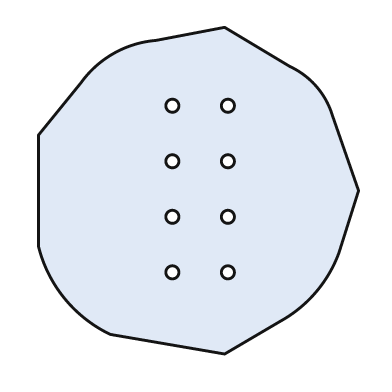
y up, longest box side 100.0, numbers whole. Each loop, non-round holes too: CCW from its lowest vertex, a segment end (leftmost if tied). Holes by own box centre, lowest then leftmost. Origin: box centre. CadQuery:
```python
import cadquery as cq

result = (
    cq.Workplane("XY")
    .moveTo(8.0, -50.0)
    .lineTo(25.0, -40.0)
    .threePointArc((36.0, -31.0), (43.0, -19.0))
    .lineTo(49.0, 0.0)
    .lineTo(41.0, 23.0)
    .threePointArc((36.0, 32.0), (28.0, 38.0))
    .lineTo(8.0, 50.0)
    .lineTo(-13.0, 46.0)
    .threePointArc((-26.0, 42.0), (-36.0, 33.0))
    .lineTo(-49.0, 17.0)
    .lineTo(-49.0, -17.0)
    .threePointArc((-41.0, -33.0), (-27.0, -44.0))
    .close()
    .moveTo(-8.0, -25.0)
    .circle(2.0)
    .moveTo(9.0, -25.0)
    .circle(2.0)
    .moveTo(-8.0, -8.0)
    .circle(2.0)
    .moveTo(9.0, -8.0)
    .circle(2.0)
    .moveTo(-8.0, 9.0)
    .circle(2.0)
    .moveTo(9.0, 9.0)
    .circle(2.0)
    .moveTo(-8.0, 26.0)
    .circle(2.0)
    .moveTo(9.0, 26.0)
    .circle(2.0)
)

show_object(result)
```